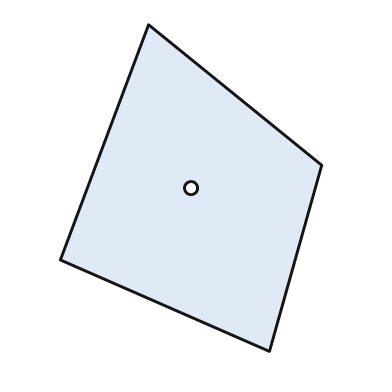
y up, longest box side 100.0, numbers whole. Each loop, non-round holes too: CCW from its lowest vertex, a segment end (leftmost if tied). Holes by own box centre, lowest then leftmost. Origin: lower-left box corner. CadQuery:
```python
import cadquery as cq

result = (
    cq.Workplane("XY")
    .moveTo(64.0, 0.0)
    .lineTo(80.0, 57.0)
    .lineTo(27.0, 100.0)
    .lineTo(0.0, 28.0)
    .close()
    .moveTo(40.0, 50.0)
    .circle(2.0)
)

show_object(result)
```